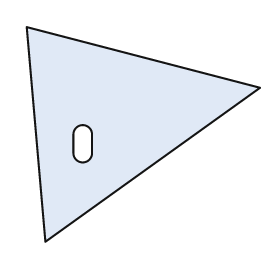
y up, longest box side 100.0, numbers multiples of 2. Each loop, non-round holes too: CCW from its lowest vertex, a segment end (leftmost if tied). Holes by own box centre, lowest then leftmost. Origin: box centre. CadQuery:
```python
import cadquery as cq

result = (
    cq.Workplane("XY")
    .moveTo(-42.0, -46.0)
    .lineTo(50.0, 20.0)
    .lineTo(-50.0, 46.0)
    .close()
    .moveTo(-30.0, -8.0)
    .threePointArc((-26.0, -12.0), (-22.0, -8.0))
    .lineTo(-22.0, 0.0)
    .threePointArc((-26.0, 4.0), (-30.0, 0.0))
    .close()
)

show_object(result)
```